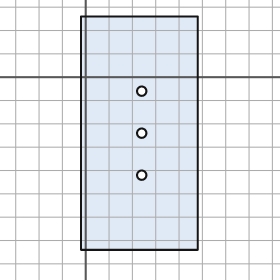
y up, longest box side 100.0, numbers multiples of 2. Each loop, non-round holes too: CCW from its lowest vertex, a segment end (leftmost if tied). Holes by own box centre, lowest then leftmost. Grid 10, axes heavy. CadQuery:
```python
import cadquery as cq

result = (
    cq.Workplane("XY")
    .moveTo(-2.0, -74.0)
    .lineTo(48.0, -74.0)
    .lineTo(48.0, 26.0)
    .lineTo(-2.0, 26.0)
    .close()
    .moveTo(24.0, -42.0)
    .circle(2.0)
    .moveTo(24.0, -24.0)
    .circle(2.0)
    .moveTo(24.0, -6.0)
    .circle(2.0)
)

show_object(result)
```